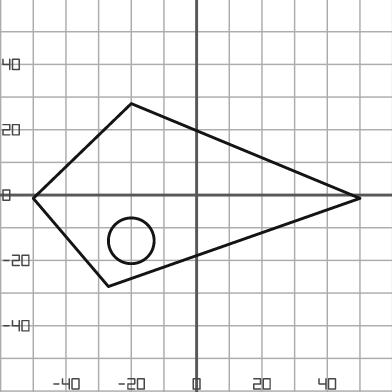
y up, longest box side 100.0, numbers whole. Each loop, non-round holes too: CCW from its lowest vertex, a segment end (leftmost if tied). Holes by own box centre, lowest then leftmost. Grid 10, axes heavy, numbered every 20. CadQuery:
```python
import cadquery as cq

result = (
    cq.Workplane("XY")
    .moveTo(-27.0, -28.0)
    .lineTo(50.0, -1.0)
    .lineTo(-20.0, 28.0)
    .lineTo(-50.0, -1.0)
    .close()
    .moveTo(-20.0, -14.0)
    .circle(7.0)
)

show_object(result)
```